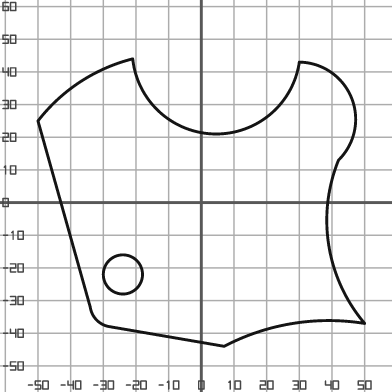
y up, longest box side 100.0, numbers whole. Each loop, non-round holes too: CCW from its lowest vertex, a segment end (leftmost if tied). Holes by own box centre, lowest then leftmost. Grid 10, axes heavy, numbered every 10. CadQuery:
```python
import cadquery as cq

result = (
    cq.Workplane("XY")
    .moveTo(7.0, -44.0)
    .threePointArc((28.0, -37.0), (50.0, -37.0))
    .threePointArc((39.0, -13.0), (42.0, 13.0))
    .threePointArc((46.0, 32.0), (30.0, 43.0))
    .threePointArc((4.0, 21.0), (-21.0, 44.0))
    .threePointArc((-37.0, 37.0), (-50.0, 25.0))
    .lineTo(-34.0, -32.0)
    .threePointArc((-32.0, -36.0), (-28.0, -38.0))
    .close()
    .moveTo(-24.0, -22.0)
    .circle(6.0)
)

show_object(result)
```